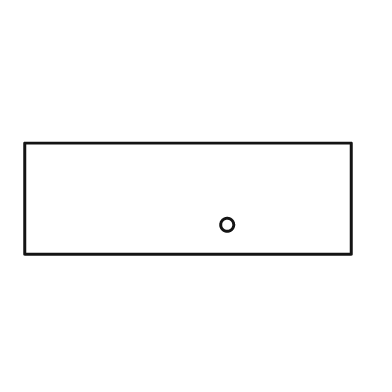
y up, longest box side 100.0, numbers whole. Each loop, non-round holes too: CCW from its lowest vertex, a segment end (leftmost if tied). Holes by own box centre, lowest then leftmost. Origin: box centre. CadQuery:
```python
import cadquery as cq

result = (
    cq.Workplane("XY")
    .moveTo(-50.0, -17.0)
    .lineTo(50.0, -17.0)
    .lineTo(50.0, 17.0)
    .lineTo(-50.0, 17.0)
    .close()
    .moveTo(12.0, -8.0)
    .circle(2.0)
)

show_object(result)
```